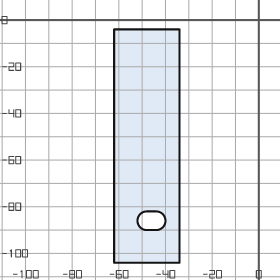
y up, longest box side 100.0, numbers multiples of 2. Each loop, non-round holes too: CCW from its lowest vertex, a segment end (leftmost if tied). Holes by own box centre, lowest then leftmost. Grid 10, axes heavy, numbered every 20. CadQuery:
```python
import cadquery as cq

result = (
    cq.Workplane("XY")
    .moveTo(-62.0, -104.0)
    .lineTo(-34.0, -104.0)
    .lineTo(-34.0, -4.0)
    .lineTo(-62.0, -4.0)
    .close()
    .moveTo(-48.0, -90.0)
    .lineTo(-44.0, -90.0)
    .threePointArc((-40.0, -86.0), (-44.0, -82.0))
    .lineTo(-48.0, -82.0)
    .threePointArc((-52.0, -86.0), (-48.0, -90.0))
    .close()
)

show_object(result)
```